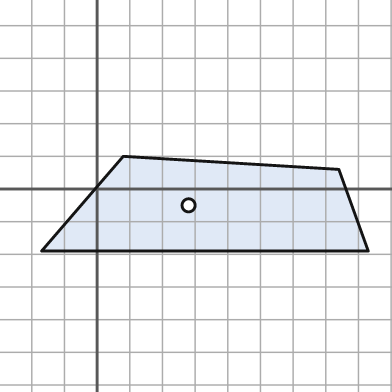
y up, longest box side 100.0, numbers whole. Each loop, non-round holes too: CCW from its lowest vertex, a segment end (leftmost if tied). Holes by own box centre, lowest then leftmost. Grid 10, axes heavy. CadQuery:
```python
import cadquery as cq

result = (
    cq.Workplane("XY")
    .moveTo(-17.0, -19.0)
    .lineTo(83.0, -19.0)
    .lineTo(74.0, 6.0)
    .lineTo(8.0, 10.0)
    .close()
    .moveTo(28.0, -5.0)
    .circle(2.0)
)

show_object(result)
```